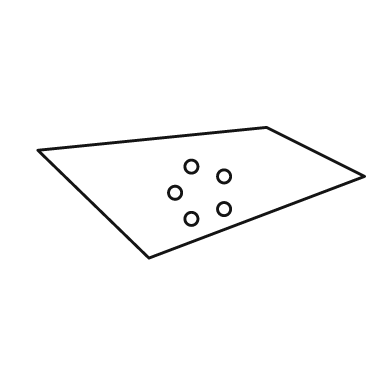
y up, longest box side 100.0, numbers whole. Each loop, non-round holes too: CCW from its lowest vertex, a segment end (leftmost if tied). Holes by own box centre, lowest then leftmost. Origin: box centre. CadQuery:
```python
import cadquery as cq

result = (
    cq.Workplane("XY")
    .moveTo(-16.0, -20.0)
    .lineTo(50.0, 5.0)
    .lineTo(20.0, 20.0)
    .lineTo(-50.0, 13.0)
    .close()
    .moveTo(-3.0, -8.0)
    .circle(2.0)
    .moveTo(7.0, -5.0)
    .circle(2.0)
    .moveTo(-8.0, 0.0)
    .circle(2.0)
    .moveTo(7.0, 5.0)
    .circle(2.0)
    .moveTo(-3.0, 8.0)
    .circle(2.0)
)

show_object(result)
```